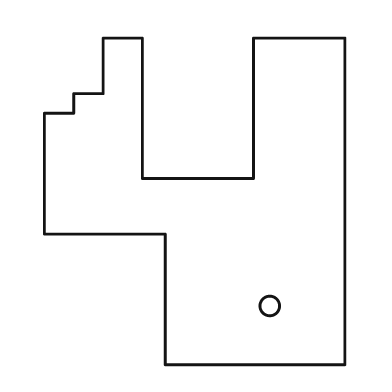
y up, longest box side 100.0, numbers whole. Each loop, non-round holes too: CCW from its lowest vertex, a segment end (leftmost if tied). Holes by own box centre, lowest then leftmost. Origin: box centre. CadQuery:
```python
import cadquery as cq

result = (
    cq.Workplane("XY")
    .moveTo(-9.0, -50.0)
    .lineTo(46.0, -50.0)
    .lineTo(46.0, 50.0)
    .lineTo(18.0, 50.0)
    .lineTo(18.0, 7.0)
    .lineTo(-16.0, 7.0)
    .lineTo(-16.0, 50.0)
    .lineTo(-28.0, 50.0)
    .lineTo(-28.0, 33.0)
    .lineTo(-37.0, 33.0)
    .lineTo(-37.0, 27.0)
    .lineTo(-46.0, 27.0)
    .lineTo(-46.0, -10.0)
    .lineTo(-9.0, -10.0)
    .close()
    .moveTo(23.0, -32.0)
    .circle(3.0)
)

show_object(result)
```